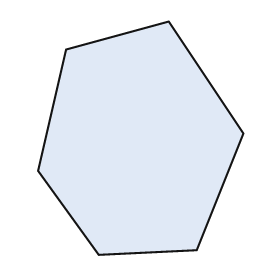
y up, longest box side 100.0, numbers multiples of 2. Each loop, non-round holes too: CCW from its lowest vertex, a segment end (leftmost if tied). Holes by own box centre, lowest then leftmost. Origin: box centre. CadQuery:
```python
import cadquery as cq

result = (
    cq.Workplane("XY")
    .moveTo(-18.0, -50.0)
    .lineTo(24.0, -48.0)
    .lineTo(44.0, 2.0)
    .lineTo(12.0, 50.0)
    .lineTo(-32.0, 38.0)
    .lineTo(-44.0, -14.0)
    .close()
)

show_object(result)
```